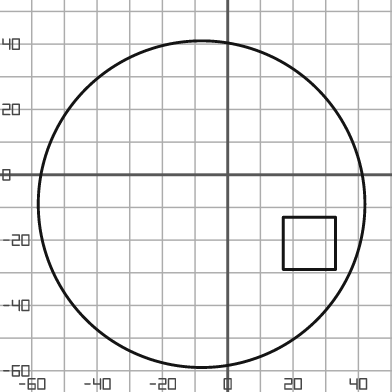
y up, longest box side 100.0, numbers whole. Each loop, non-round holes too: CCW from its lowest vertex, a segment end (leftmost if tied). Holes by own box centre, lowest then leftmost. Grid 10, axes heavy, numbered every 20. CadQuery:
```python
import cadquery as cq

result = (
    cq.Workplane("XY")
    .moveTo(-8.0, -9.0)
    .circle(50.0)
    .moveTo(17.0, -29.0)
    .lineTo(33.0, -29.0)
    .lineTo(33.0, -13.0)
    .lineTo(17.0, -13.0)
    .close()
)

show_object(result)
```